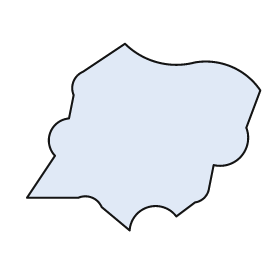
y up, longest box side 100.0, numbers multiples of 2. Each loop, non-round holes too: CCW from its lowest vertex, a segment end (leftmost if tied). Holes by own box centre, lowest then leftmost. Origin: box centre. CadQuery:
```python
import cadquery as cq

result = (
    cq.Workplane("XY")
    .moveTo(-6.0, -40.0)
    .threePointArc((2.0, -30.0), (14.0, -34.0))
    .lineTo(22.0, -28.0)
    .threePointArc((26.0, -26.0), (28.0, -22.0))
    .lineTo(30.0, -12.0)
    .threePointArc((42.0, -8.0), (44.0, 4.0))
    .lineTo(50.0, 20.0)
    .threePointArc((38.0, 30.0), (22.0, 32.0))
    .threePointArc((6.0, 32.0), (-8.0, 40.0))
    .lineTo(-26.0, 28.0)
    .threePointArc((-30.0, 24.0), (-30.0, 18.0))
    .lineTo(-32.0, 8.0)
    .threePointArc((-40.0, 2.0), (-38.0, -8.0))
    .lineTo(-50.0, -26.0)
    .lineTo(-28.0, -26.0)
    .threePointArc((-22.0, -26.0), (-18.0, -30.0))
    .close()
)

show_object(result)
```